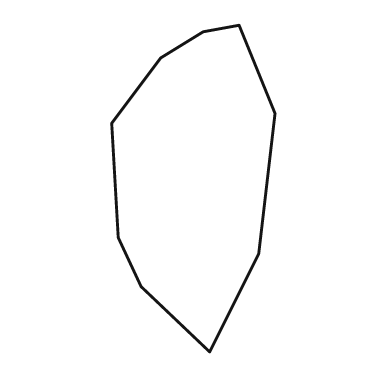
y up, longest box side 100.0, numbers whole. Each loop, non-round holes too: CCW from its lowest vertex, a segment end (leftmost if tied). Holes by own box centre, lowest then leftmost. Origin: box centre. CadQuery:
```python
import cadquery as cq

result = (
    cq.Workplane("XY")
    .moveTo(5.0, -50.0)
    .lineTo(20.0, -20.0)
    .lineTo(25.0, 23.0)
    .lineTo(14.0, 50.0)
    .lineTo(3.0, 48.0)
    .lineTo(-10.0, 40.0)
    .lineTo(-25.0, 20.0)
    .lineTo(-23.0, -15.0)
    .lineTo(-16.0, -30.0)
    .close()
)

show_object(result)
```